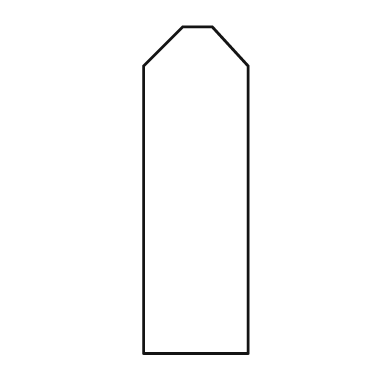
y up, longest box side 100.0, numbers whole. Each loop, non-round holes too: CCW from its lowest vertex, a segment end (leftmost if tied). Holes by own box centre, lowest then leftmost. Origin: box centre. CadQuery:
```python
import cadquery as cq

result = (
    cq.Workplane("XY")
    .moveTo(-16.0, -50.0)
    .lineTo(16.0, -50.0)
    .lineTo(16.0, 38.0)
    .lineTo(5.0, 50.0)
    .lineTo(-4.0, 50.0)
    .lineTo(-16.0, 38.0)
    .close()
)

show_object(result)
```